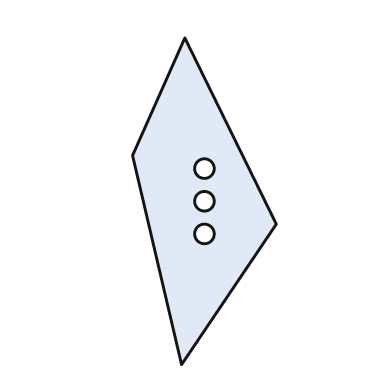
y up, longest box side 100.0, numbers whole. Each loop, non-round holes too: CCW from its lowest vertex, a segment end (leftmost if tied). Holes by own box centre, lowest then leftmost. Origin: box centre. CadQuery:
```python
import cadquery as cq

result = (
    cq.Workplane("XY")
    .moveTo(-7.0, -50.0)
    .lineTo(22.0, -7.0)
    .lineTo(-6.0, 50.0)
    .lineTo(-22.0, 14.0)
    .close()
    .moveTo(0.0, -10.0)
    .circle(3.0)
    .moveTo(0.0, 0.0)
    .circle(3.0)
    .moveTo(0.0, 10.0)
    .circle(3.0)
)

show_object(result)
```